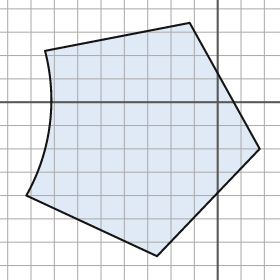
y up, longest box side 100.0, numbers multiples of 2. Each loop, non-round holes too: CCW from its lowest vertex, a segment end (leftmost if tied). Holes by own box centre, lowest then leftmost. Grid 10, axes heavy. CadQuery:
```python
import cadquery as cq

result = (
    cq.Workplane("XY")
    .moveTo(-26.0, -66.0)
    .lineTo(18.0, -20.0)
    .lineTo(-12.0, 34.0)
    .lineTo(-74.0, 22.0)
    .threePointArc((-72.0, -10.0), (-82.0, -40.0))
    .close()
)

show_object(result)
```